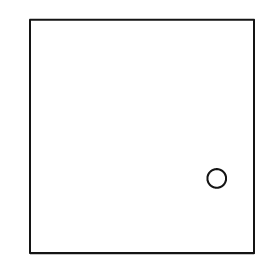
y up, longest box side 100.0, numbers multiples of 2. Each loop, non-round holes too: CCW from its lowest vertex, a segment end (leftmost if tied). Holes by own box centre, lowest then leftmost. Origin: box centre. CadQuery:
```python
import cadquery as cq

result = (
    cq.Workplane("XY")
    .moveTo(-48.0, -50.0)
    .lineTo(48.0, -50.0)
    .lineTo(48.0, 50.0)
    .lineTo(-48.0, 50.0)
    .close()
    .moveTo(32.0, -18.0)
    .circle(4.0)
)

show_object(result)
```